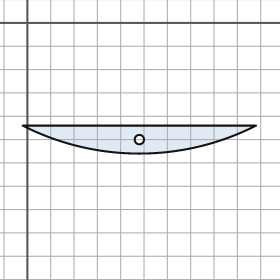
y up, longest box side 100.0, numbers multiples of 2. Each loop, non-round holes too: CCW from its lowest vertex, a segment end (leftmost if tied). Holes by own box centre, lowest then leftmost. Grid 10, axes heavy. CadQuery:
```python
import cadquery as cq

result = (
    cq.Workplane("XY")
    .moveTo(-2.0, -44.0)
    .threePointArc((48.0, -56.0), (98.0, -44.0))
    .close()
    .moveTo(48.0, -50.0)
    .circle(2.0)
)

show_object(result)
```